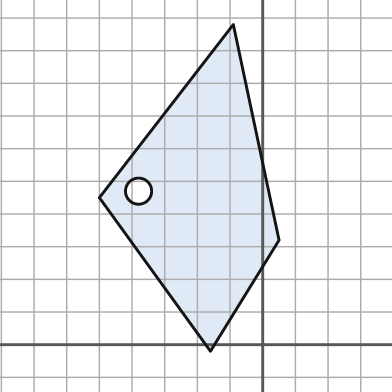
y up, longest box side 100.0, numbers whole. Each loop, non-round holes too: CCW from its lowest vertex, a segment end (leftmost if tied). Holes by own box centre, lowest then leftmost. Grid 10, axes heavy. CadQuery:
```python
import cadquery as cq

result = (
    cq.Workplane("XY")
    .moveTo(-16.0, -2.0)
    .lineTo(5.0, 32.0)
    .lineTo(-9.0, 98.0)
    .lineTo(-50.0, 45.0)
    .close()
    .moveTo(-38.0, 47.0)
    .circle(4.0)
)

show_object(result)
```